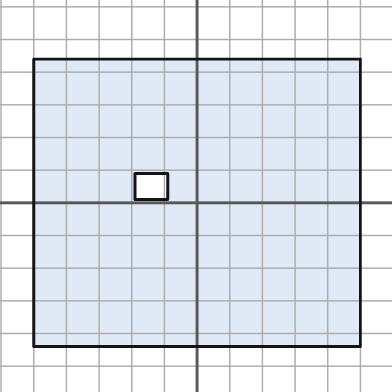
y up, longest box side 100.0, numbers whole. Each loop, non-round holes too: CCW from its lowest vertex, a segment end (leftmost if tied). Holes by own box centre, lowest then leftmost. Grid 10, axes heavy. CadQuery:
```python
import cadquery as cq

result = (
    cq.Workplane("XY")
    .moveTo(-50.0, -44.0)
    .lineTo(50.0, -44.0)
    .lineTo(50.0, 44.0)
    .lineTo(-50.0, 44.0)
    .close()
    .moveTo(-19.0, 1.0)
    .lineTo(-9.0, 1.0)
    .lineTo(-9.0, 9.0)
    .lineTo(-19.0, 9.0)
    .close()
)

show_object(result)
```